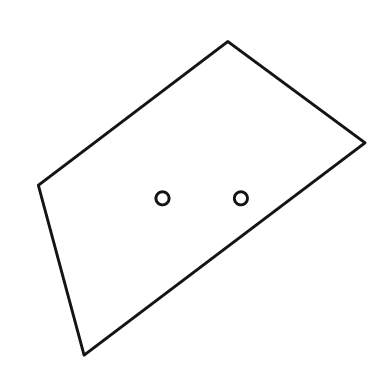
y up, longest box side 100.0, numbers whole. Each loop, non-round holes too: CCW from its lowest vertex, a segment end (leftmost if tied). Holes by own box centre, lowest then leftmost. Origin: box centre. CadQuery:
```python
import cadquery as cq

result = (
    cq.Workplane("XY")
    .moveTo(-36.0, -48.0)
    .lineTo(50.0, 17.0)
    .lineTo(8.0, 48.0)
    .lineTo(-50.0, 4.0)
    .close()
    .moveTo(-12.0, 0.0)
    .circle(2.0)
    .moveTo(12.0, 0.0)
    .circle(2.0)
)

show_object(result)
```